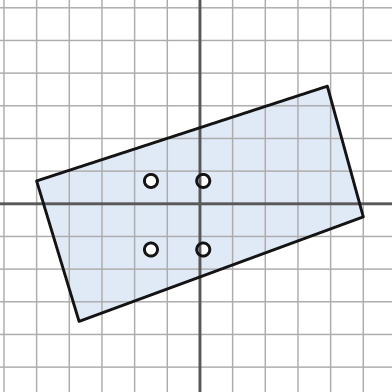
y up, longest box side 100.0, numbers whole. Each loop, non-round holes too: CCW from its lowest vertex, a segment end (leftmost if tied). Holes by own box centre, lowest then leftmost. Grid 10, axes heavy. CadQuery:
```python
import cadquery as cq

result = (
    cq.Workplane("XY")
    .moveTo(-37.0, -36.0)
    .lineTo(50.0, -4.0)
    .lineTo(39.0, 36.0)
    .lineTo(-50.0, 7.0)
    .close()
    .moveTo(-15.0, -14.0)
    .circle(2.0)
    .moveTo(1.0, -14.0)
    .circle(2.0)
    .moveTo(-15.0, 7.0)
    .circle(2.0)
    .moveTo(1.0, 7.0)
    .circle(2.0)
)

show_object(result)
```